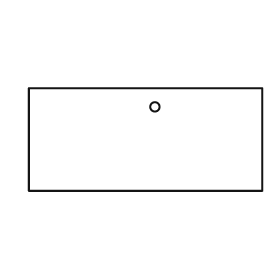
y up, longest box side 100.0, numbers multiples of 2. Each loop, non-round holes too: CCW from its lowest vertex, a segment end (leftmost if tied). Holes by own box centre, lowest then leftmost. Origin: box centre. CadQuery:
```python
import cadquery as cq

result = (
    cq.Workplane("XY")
    .moveTo(-50.0, -22.0)
    .lineTo(50.0, -22.0)
    .lineTo(50.0, 22.0)
    .lineTo(-50.0, 22.0)
    .close()
    .moveTo(4.0, 14.0)
    .circle(2.0)
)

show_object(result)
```